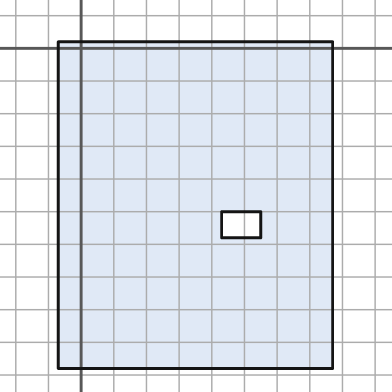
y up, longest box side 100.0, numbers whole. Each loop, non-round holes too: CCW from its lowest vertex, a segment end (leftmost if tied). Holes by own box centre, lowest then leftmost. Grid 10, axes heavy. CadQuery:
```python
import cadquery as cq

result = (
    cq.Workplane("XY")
    .moveTo(-7.0, -98.0)
    .lineTo(77.0, -98.0)
    .lineTo(77.0, 2.0)
    .lineTo(-7.0, 2.0)
    .close()
    .moveTo(43.0, -58.0)
    .lineTo(55.0, -58.0)
    .lineTo(55.0, -50.0)
    .lineTo(43.0, -50.0)
    .close()
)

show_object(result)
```